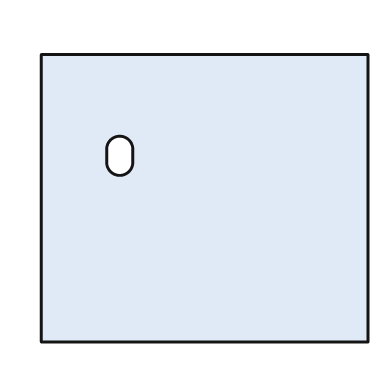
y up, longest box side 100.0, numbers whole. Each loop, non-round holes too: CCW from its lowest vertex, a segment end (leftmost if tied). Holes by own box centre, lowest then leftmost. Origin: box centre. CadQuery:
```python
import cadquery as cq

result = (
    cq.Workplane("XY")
    .moveTo(-50.0, -44.0)
    .lineTo(50.0, -44.0)
    .lineTo(50.0, 44.0)
    .lineTo(-50.0, 44.0)
    .close()
    .moveTo(-30.0, 11.0)
    .threePointArc((-26.0, 7.0), (-22.0, 11.0))
    .lineTo(-22.0, 15.0)
    .threePointArc((-26.0, 19.0), (-30.0, 15.0))
    .close()
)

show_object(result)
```